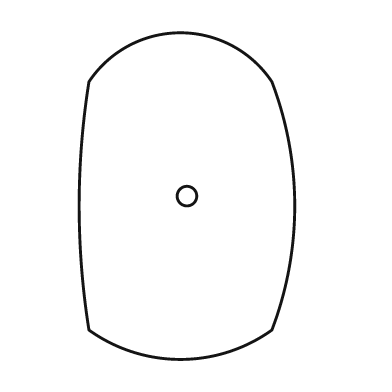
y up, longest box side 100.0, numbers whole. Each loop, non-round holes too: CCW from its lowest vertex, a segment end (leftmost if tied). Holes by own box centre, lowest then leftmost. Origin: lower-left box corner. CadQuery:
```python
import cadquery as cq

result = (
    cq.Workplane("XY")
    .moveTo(3.0, 9.0)
    .threePointArc((31.0, 0.0), (59.0, 9.0))
    .threePointArc((66.0, 47.0), (59.0, 85.0))
    .threePointArc((31.0, 100.0), (3.0, 85.0))
    .threePointArc((0.0, 47.0), (3.0, 9.0))
    .close()
    .moveTo(33.0, 50.0)
    .circle(3.0)
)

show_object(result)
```